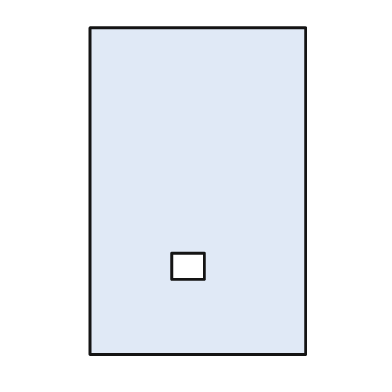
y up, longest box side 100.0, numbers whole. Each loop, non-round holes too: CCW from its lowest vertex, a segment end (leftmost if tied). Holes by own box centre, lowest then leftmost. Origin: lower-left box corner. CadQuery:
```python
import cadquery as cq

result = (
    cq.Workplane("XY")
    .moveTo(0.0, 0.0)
    .lineTo(66.0, 0.0)
    .lineTo(66.0, 100.0)
    .lineTo(0.0, 100.0)
    .close()
    .moveTo(25.0, 23.0)
    .lineTo(35.0, 23.0)
    .lineTo(35.0, 31.0)
    .lineTo(25.0, 31.0)
    .close()
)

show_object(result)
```